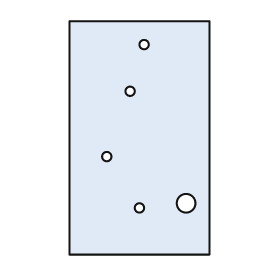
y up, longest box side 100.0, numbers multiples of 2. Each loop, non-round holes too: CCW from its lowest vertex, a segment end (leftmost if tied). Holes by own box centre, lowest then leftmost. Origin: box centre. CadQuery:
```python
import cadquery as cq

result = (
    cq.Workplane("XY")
    .moveTo(-30.0, -50.0)
    .lineTo(30.0, -50.0)
    .lineTo(30.0, 50.0)
    .lineTo(-30.0, 50.0)
    .close()
    .moveTo(0.0, -30.0)
    .circle(2.0)
    .moveTo(20.0, -28.0)
    .circle(4.0)
    .moveTo(-14.0, -8.0)
    .circle(2.0)
    .moveTo(-4.0, 20.0)
    .circle(2.0)
    .moveTo(2.0, 40.0)
    .circle(2.0)
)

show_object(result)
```